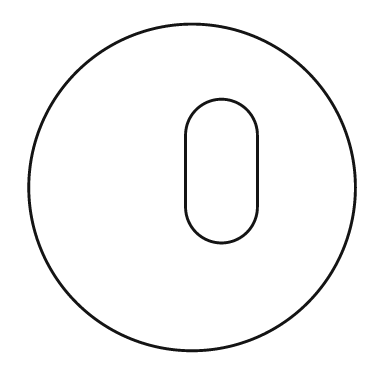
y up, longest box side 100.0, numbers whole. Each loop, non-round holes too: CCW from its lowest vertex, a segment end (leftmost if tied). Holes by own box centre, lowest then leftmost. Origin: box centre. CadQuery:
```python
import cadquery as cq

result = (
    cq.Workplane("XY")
    .moveTo(0.0, 0.0)
    .circle(50.0)
    .moveTo(-2.0, -6.0)
    .threePointArc((9.0, -17.0), (20.0, -6.0))
    .lineTo(20.0, 16.0)
    .threePointArc((9.0, 27.0), (-2.0, 16.0))
    .close()
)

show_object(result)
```